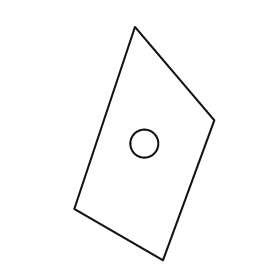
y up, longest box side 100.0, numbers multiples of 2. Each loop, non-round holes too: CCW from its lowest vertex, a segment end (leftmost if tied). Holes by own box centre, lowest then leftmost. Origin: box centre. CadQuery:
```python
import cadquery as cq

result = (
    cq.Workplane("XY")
    .moveTo(8.0, -50.0)
    .lineTo(30.0, 10.0)
    .lineTo(-4.0, 50.0)
    .lineTo(-30.0, -28.0)
    .close()
    .moveTo(0.0, 0.0)
    .circle(6.0)
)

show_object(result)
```